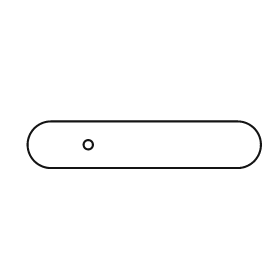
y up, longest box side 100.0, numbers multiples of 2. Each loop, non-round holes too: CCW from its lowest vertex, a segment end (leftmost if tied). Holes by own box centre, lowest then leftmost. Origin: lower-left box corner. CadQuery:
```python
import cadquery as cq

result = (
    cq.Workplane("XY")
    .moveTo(10.0, 0.0)
    .lineTo(90.0, 0.0)
    .threePointArc((100.0, 10.0), (90.0, 20.0))
    .lineTo(10.0, 20.0)
    .threePointArc((0.0, 10.0), (10.0, 0.0))
    .close()
    .moveTo(26.0, 10.0)
    .circle(2.0)
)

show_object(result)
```